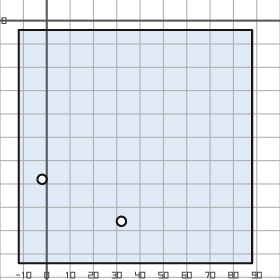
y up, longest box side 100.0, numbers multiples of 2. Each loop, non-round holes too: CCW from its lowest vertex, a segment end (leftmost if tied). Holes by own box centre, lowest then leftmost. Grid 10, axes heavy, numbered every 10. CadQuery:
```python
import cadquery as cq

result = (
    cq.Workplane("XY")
    .moveTo(-12.0, -104.0)
    .lineTo(88.0, -104.0)
    .lineTo(88.0, -4.0)
    .lineTo(-12.0, -4.0)
    .close()
    .moveTo(32.0, -86.0)
    .circle(2.0)
    .moveTo(-2.0, -68.0)
    .circle(2.0)
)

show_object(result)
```